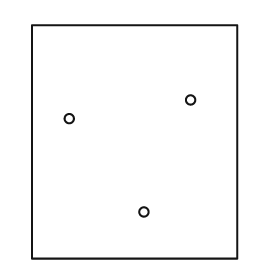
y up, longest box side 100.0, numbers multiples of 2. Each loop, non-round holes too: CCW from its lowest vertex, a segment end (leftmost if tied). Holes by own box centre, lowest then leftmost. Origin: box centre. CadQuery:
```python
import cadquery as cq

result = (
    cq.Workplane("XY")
    .moveTo(-44.0, -50.0)
    .lineTo(44.0, -50.0)
    .lineTo(44.0, 50.0)
    .lineTo(-44.0, 50.0)
    .close()
    .moveTo(4.0, -30.0)
    .circle(2.0)
    .moveTo(-28.0, 10.0)
    .circle(2.0)
    .moveTo(24.0, 18.0)
    .circle(2.0)
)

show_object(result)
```